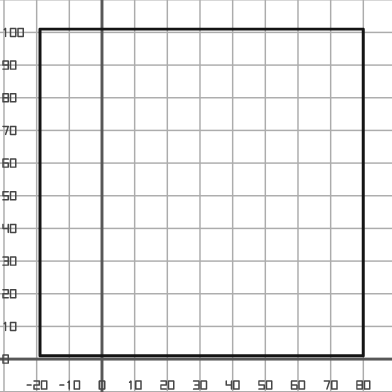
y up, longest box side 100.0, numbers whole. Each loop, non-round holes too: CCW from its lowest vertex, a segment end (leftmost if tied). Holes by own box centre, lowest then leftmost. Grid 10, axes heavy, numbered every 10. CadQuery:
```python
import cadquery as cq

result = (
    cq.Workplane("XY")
    .moveTo(-19.0, 1.0)
    .lineTo(80.0, 1.0)
    .lineTo(80.0, 101.0)
    .lineTo(-19.0, 101.0)
    .close()
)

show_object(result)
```